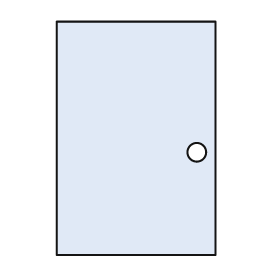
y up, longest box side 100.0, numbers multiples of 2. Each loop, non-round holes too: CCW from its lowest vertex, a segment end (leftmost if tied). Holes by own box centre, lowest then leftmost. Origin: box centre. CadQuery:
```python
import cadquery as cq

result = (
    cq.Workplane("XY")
    .moveTo(-34.0, -50.0)
    .lineTo(34.0, -50.0)
    .lineTo(34.0, 50.0)
    .lineTo(-34.0, 50.0)
    .close()
    .moveTo(26.0, -6.0)
    .circle(4.0)
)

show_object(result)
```